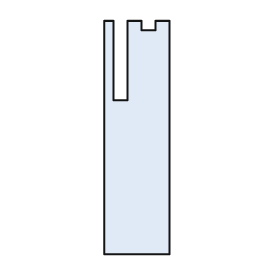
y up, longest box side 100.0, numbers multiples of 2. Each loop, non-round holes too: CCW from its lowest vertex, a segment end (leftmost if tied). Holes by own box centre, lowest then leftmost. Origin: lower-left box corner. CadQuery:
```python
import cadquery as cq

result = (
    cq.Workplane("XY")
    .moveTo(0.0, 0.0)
    .lineTo(28.0, 0.0)
    .lineTo(28.0, 100.0)
    .lineTo(22.0, 100.0)
    .lineTo(22.0, 96.0)
    .lineTo(16.0, 96.0)
    .lineTo(16.0, 100.0)
    .lineTo(10.0, 100.0)
    .lineTo(10.0, 66.0)
    .lineTo(4.0, 66.0)
    .lineTo(4.0, 100.0)
    .lineTo(0.0, 100.0)
    .close()
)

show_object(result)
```